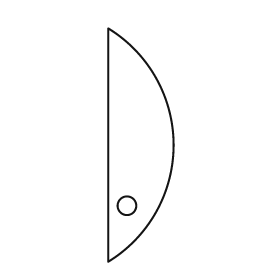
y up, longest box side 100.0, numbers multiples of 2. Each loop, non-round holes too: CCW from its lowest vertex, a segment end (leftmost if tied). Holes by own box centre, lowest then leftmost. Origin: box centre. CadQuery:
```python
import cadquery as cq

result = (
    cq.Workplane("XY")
    .moveTo(-14.0, -50.0)
    .threePointArc((14.0, 0.0), (-14.0, 50.0))
    .close()
    .moveTo(-6.0, -26.0)
    .circle(4.0)
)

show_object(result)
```